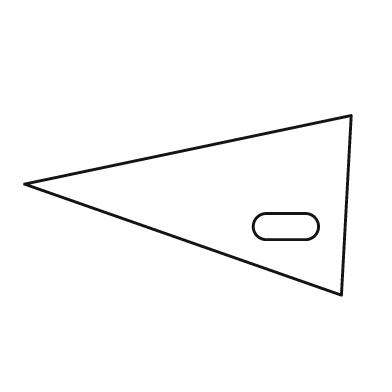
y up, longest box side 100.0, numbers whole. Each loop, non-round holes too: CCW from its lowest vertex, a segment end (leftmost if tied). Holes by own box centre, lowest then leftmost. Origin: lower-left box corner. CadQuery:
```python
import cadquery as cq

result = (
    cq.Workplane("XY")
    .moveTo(97.0, 0.0)
    .lineTo(100.0, 55.0)
    .lineTo(0.0, 34.0)
    .close()
    .moveTo(74.0, 17.0)
    .lineTo(86.0, 17.0)
    .threePointArc((90.0, 21.0), (86.0, 25.0))
    .lineTo(74.0, 25.0)
    .threePointArc((70.0, 21.0), (74.0, 17.0))
    .close()
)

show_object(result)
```